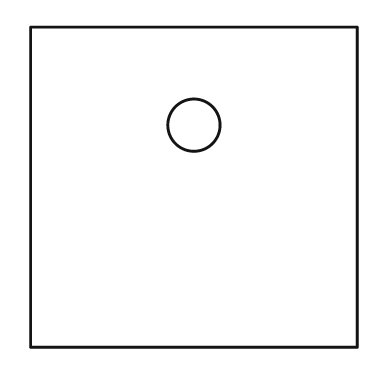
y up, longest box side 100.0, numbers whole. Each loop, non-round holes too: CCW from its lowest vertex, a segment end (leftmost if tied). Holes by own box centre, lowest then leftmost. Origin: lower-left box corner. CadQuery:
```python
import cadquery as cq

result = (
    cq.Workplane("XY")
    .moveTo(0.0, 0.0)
    .lineTo(100.0, 0.0)
    .lineTo(100.0, 98.0)
    .lineTo(0.0, 98.0)
    .close()
    .moveTo(50.0, 68.0)
    .circle(8.0)
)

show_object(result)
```